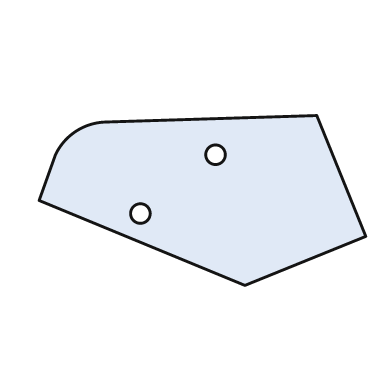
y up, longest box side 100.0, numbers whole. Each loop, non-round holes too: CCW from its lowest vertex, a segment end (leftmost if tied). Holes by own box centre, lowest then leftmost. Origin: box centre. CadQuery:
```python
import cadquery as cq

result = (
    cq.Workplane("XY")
    .moveTo(13.0, -26.0)
    .lineTo(50.0, -11.0)
    .lineTo(35.0, 26.0)
    .lineTo(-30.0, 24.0)
    .threePointArc((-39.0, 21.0), (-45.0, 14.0))
    .lineTo(-50.0, 0.0)
    .close()
    .moveTo(-19.0, -4.0)
    .circle(3.0)
    .moveTo(4.0, 14.0)
    .circle(3.0)
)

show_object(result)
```